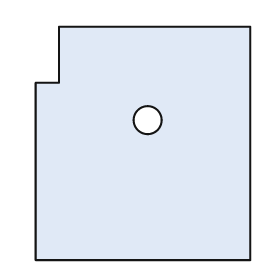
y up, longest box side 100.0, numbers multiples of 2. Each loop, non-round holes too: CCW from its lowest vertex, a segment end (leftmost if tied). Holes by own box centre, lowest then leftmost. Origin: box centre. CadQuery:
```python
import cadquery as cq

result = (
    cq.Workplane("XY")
    .moveTo(-46.0, -50.0)
    .lineTo(46.0, -50.0)
    .lineTo(46.0, 50.0)
    .lineTo(-36.0, 50.0)
    .lineTo(-36.0, 26.0)
    .lineTo(-46.0, 26.0)
    .close()
    .moveTo(2.0, 10.0)
    .circle(6.0)
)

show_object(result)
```